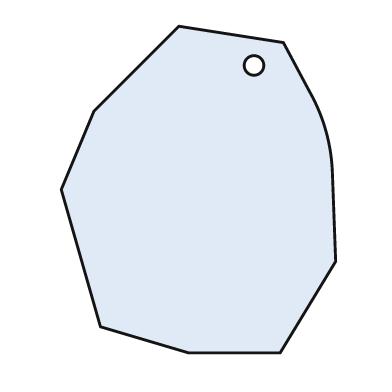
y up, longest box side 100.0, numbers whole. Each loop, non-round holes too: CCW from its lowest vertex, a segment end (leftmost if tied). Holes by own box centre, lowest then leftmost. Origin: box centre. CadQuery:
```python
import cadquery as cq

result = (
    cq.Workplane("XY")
    .moveTo(-3.0, -50.0)
    .lineTo(25.0, -50.0)
    .lineTo(42.0, -22.0)
    .lineTo(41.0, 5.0)
    .threePointArc((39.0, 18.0), (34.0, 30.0))
    .lineTo(26.0, 45.0)
    .lineTo(-6.0, 50.0)
    .lineTo(-32.0, 24.0)
    .lineTo(-42.0, 0.0)
    .lineTo(-30.0, -42.0)
    .close()
    .moveTo(17.0, 38.0)
    .circle(3.0)
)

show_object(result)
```